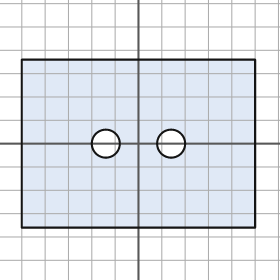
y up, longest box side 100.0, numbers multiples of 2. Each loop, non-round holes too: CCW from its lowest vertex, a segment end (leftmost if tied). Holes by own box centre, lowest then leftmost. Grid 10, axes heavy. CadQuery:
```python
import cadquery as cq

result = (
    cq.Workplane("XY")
    .moveTo(-50.0, -36.0)
    .lineTo(50.0, -36.0)
    .lineTo(50.0, 36.0)
    .lineTo(-50.0, 36.0)
    .close()
    .moveTo(-14.0, 0.0)
    .circle(6.0)
    .moveTo(14.0, 0.0)
    .circle(6.0)
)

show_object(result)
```